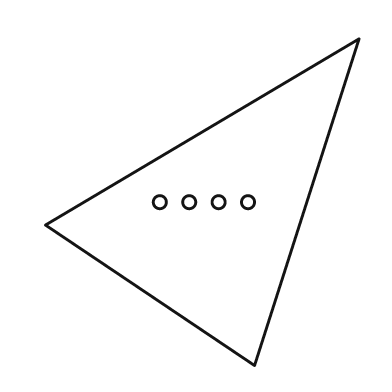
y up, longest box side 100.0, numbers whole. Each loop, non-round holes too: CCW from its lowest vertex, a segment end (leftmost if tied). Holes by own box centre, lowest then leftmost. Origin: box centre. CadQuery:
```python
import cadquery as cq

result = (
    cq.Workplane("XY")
    .moveTo(16.0, -50.0)
    .lineTo(48.0, 50.0)
    .lineTo(-48.0, -7.0)
    .close()
    .moveTo(-13.0, 0.0)
    .circle(2.0)
    .moveTo(-4.0, 0.0)
    .circle(2.0)
    .moveTo(5.0, 0.0)
    .circle(2.0)
    .moveTo(14.0, 0.0)
    .circle(2.0)
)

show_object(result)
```